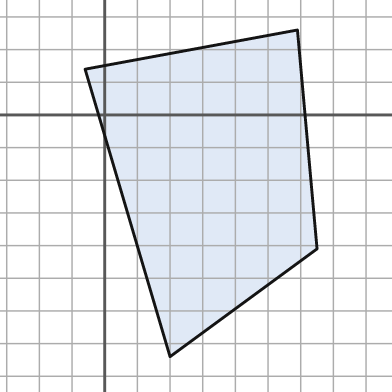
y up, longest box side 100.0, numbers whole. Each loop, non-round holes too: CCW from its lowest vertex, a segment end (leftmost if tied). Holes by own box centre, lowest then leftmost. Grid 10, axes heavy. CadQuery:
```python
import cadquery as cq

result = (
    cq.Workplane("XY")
    .moveTo(20.0, -74.0)
    .lineTo(65.0, -41.0)
    .lineTo(59.0, 26.0)
    .lineTo(-6.0, 14.0)
    .close()
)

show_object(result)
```